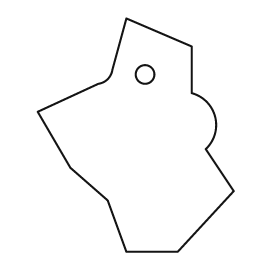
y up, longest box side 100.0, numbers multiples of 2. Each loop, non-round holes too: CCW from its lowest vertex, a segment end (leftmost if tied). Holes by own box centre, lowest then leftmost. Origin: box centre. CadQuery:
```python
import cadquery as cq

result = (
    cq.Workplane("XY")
    .moveTo(-4.0, -50.0)
    .lineTo(18.0, -50.0)
    .lineTo(42.0, -24.0)
    .lineTo(30.0, -6.0)
    .threePointArc((34.0, 8.0), (24.0, 18.0))
    .lineTo(24.0, 38.0)
    .lineTo(-4.0, 50.0)
    .lineTo(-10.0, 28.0)
    .threePointArc((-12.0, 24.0), (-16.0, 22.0))
    .lineTo(-42.0, 10.0)
    .lineTo(-28.0, -14.0)
    .lineTo(-12.0, -28.0)
    .close()
    .moveTo(4.0, 26.0)
    .circle(4.0)
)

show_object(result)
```